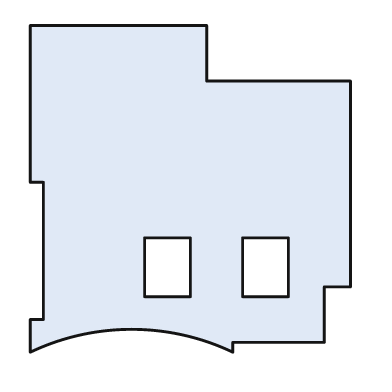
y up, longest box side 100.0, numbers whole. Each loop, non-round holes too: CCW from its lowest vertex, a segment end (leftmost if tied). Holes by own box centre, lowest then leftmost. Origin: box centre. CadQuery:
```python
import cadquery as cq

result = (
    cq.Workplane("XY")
    .moveTo(-49.0, -50.0)
    .threePointArc((-18.0, -43.0), (13.0, -50.0))
    .lineTo(13.0, -47.0)
    .lineTo(41.0, -47.0)
    .lineTo(41.0, -30.0)
    .lineTo(49.0, -30.0)
    .lineTo(49.0, 33.0)
    .lineTo(5.0, 33.0)
    .lineTo(5.0, 50.0)
    .lineTo(-49.0, 50.0)
    .lineTo(-49.0, 2.0)
    .lineTo(-45.0, 2.0)
    .lineTo(-45.0, -40.0)
    .lineTo(-49.0, -40.0)
    .close()
    .moveTo(-14.0, -33.0)
    .lineTo(0.0, -33.0)
    .lineTo(0.0, -15.0)
    .lineTo(-14.0, -15.0)
    .close()
    .moveTo(16.0, -33.0)
    .lineTo(30.0, -33.0)
    .lineTo(30.0, -15.0)
    .lineTo(16.0, -15.0)
    .close()
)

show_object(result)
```